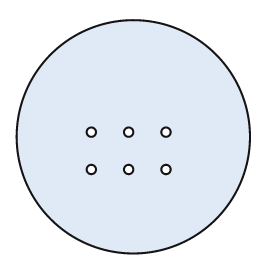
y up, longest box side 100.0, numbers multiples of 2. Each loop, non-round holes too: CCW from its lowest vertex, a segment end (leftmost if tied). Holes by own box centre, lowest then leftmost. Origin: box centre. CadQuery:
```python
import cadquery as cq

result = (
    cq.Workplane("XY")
    .moveTo(0.0, 0.0)
    .circle(50.0)
    .moveTo(-18.0, -14.0)
    .circle(2.0)
    .moveTo(-2.0, -14.0)
    .circle(2.0)
    .moveTo(14.0, -14.0)
    .circle(2.0)
    .moveTo(-18.0, 2.0)
    .circle(2.0)
    .moveTo(-2.0, 2.0)
    .circle(2.0)
    .moveTo(14.0, 2.0)
    .circle(2.0)
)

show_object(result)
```